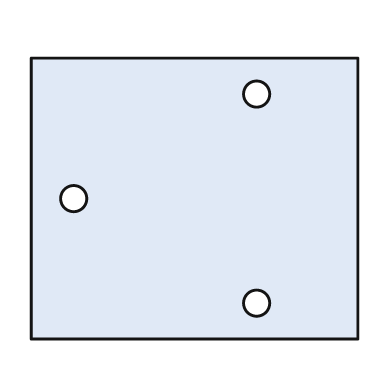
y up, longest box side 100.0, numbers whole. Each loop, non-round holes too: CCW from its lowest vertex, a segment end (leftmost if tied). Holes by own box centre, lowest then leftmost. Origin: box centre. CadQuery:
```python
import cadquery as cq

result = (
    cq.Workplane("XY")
    .moveTo(-50.0, -43.0)
    .lineTo(50.0, -43.0)
    .lineTo(50.0, 43.0)
    .lineTo(-50.0, 43.0)
    .close()
    .moveTo(19.0, -32.0)
    .circle(4.0)
    .moveTo(-37.0, 0.0)
    .circle(4.0)
    .moveTo(19.0, 32.0)
    .circle(4.0)
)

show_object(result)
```